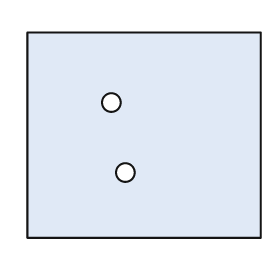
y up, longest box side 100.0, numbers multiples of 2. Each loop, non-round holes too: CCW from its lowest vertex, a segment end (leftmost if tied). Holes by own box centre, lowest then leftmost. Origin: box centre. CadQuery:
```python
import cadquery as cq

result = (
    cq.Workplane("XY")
    .moveTo(-50.0, -44.0)
    .lineTo(50.0, -44.0)
    .lineTo(50.0, 44.0)
    .lineTo(-50.0, 44.0)
    .close()
    .moveTo(-8.0, -16.0)
    .circle(4.0)
    .moveTo(-14.0, 14.0)
    .circle(4.0)
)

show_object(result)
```